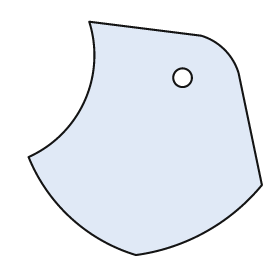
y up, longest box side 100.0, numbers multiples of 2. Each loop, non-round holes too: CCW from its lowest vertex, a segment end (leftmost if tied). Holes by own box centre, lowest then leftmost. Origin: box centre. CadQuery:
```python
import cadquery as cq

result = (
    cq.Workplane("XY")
    .moveTo(-4.0, -50.0)
    .threePointArc((26.0, -40.0), (50.0, -20.0))
    .lineTo(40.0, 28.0)
    .threePointArc((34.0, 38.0), (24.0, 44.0))
    .lineTo(-24.0, 50.0)
    .threePointArc((-26.0, 16.0), (-50.0, -8.0))
    .threePointArc((-32.0, -34.0), (-4.0, -50.0))
    .close()
    .moveTo(16.0, 26.0)
    .circle(4.0)
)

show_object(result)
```